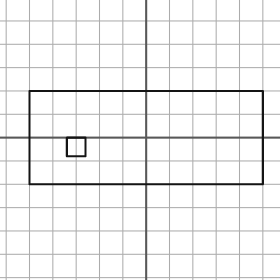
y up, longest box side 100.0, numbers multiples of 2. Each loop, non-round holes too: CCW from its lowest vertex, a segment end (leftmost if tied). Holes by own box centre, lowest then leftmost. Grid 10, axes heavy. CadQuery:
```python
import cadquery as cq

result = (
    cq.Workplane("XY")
    .moveTo(-50.0, -20.0)
    .lineTo(50.0, -20.0)
    .lineTo(50.0, 20.0)
    .lineTo(-50.0, 20.0)
    .close()
    .moveTo(-34.0, -8.0)
    .lineTo(-26.0, -8.0)
    .lineTo(-26.0, 0.0)
    .lineTo(-34.0, 0.0)
    .close()
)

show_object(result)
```